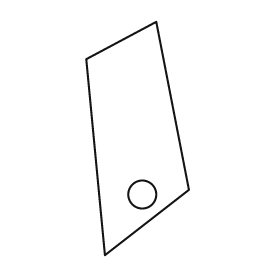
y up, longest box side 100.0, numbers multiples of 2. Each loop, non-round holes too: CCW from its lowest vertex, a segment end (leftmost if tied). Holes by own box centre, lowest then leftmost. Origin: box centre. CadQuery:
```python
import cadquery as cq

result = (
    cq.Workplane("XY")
    .moveTo(-14.0, -50.0)
    .lineTo(22.0, -22.0)
    .lineTo(8.0, 50.0)
    .lineTo(-22.0, 34.0)
    .close()
    .moveTo(2.0, -24.0)
    .circle(6.0)
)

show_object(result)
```